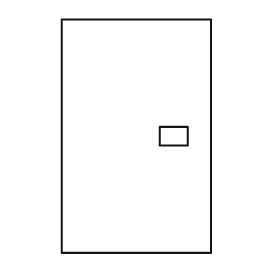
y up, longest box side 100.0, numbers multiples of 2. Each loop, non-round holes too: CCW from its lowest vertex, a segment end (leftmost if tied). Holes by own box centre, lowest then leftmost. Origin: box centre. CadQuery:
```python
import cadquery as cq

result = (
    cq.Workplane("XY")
    .moveTo(-32.0, -50.0)
    .lineTo(32.0, -50.0)
    .lineTo(32.0, 50.0)
    .lineTo(-32.0, 50.0)
    .close()
    .moveTo(10.0, -4.0)
    .lineTo(22.0, -4.0)
    .lineTo(22.0, 4.0)
    .lineTo(10.0, 4.0)
    .close()
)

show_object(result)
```